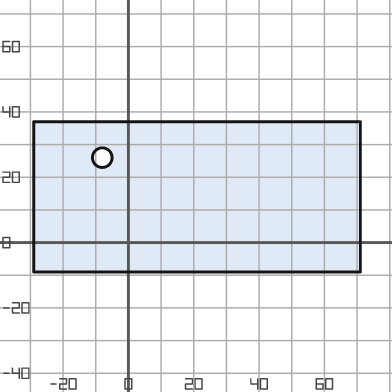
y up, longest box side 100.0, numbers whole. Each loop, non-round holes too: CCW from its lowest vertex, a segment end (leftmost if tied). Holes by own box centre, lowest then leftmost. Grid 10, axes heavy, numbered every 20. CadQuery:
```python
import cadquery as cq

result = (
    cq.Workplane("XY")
    .moveTo(-29.0, -9.0)
    .lineTo(71.0, -9.0)
    .lineTo(71.0, 37.0)
    .lineTo(-29.0, 37.0)
    .close()
    .moveTo(-8.0, 26.0)
    .circle(3.0)
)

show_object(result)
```